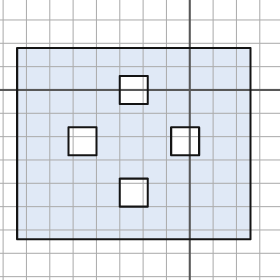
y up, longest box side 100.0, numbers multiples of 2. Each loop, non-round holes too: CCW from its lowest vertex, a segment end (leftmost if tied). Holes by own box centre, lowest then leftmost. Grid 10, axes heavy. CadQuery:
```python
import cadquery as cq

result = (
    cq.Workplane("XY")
    .moveTo(-74.0, -64.0)
    .lineTo(26.0, -64.0)
    .lineTo(26.0, 18.0)
    .lineTo(-74.0, 18.0)
    .close()
    .moveTo(-30.0, -50.0)
    .lineTo(-18.0, -50.0)
    .lineTo(-18.0, -38.0)
    .lineTo(-30.0, -38.0)
    .close()
    .moveTo(-52.0, -28.0)
    .lineTo(-40.0, -28.0)
    .lineTo(-40.0, -16.0)
    .lineTo(-52.0, -16.0)
    .close()
    .moveTo(-8.0, -28.0)
    .lineTo(4.0, -28.0)
    .lineTo(4.0, -16.0)
    .lineTo(-8.0, -16.0)
    .close()
    .moveTo(-30.0, -6.0)
    .lineTo(-18.0, -6.0)
    .lineTo(-18.0, 6.0)
    .lineTo(-30.0, 6.0)
    .close()
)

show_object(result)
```